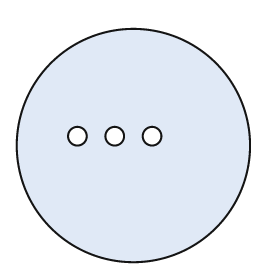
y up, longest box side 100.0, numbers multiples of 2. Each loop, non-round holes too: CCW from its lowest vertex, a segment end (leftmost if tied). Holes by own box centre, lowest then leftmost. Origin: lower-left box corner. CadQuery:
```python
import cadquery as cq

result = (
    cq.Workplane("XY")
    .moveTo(50.0, 50.0)
    .circle(50.0)
    .moveTo(26.0, 54.0)
    .circle(4.0)
    .moveTo(42.0, 54.0)
    .circle(4.0)
    .moveTo(58.0, 54.0)
    .circle(4.0)
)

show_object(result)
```